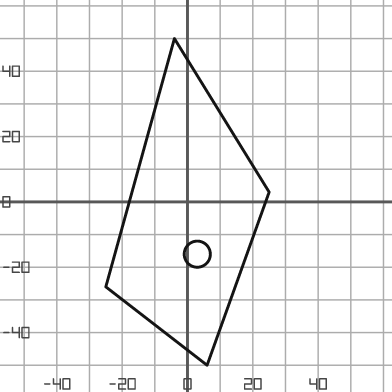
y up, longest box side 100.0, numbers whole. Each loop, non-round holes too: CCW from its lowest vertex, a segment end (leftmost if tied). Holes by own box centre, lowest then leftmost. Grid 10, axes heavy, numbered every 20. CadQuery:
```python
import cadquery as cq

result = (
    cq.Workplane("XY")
    .moveTo(6.0, -50.0)
    .lineTo(25.0, 3.0)
    .lineTo(-4.0, 50.0)
    .lineTo(-25.0, -26.0)
    .close()
    .moveTo(3.0, -16.0)
    .circle(4.0)
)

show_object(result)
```